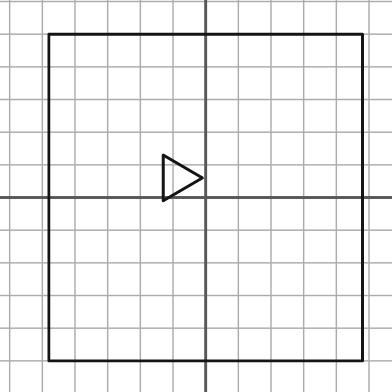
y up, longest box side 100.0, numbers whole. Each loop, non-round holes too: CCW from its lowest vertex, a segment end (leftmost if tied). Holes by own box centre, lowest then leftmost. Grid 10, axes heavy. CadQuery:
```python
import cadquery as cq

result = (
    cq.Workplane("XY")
    .moveTo(-48.0, -50.0)
    .lineTo(48.0, -50.0)
    .lineTo(48.0, 50.0)
    .lineTo(-48.0, 50.0)
    .close()
    .moveTo(-13.0, -1.0)
    .lineTo(-1.0, 6.0)
    .lineTo(-13.0, 13.0)
    .close()
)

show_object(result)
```